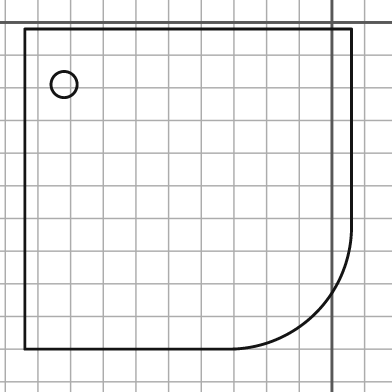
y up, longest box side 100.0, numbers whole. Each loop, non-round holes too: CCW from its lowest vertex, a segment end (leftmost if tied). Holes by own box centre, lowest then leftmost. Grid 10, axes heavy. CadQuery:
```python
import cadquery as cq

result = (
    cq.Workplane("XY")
    .moveTo(-94.0, -100.0)
    .lineTo(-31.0, -100.0)
    .threePointArc((-5.0, -89.0), (6.0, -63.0))
    .lineTo(6.0, -2.0)
    .lineTo(-94.0, -2.0)
    .close()
    .moveTo(-82.0, -19.0)
    .circle(4.0)
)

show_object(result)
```